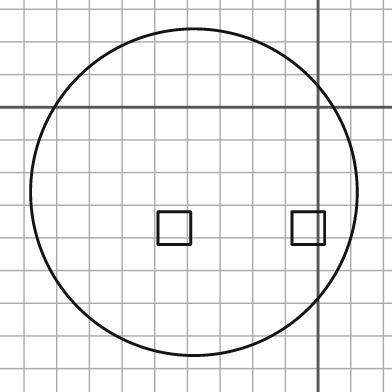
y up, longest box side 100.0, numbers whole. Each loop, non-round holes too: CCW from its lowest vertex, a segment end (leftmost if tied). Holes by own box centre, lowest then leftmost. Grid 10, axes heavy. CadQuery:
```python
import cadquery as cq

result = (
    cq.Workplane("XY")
    .moveTo(-38.0, -26.0)
    .circle(50.0)
    .moveTo(-49.0, -42.0)
    .lineTo(-39.0, -42.0)
    .lineTo(-39.0, -32.0)
    .lineTo(-49.0, -32.0)
    .close()
    .moveTo(-8.0, -42.0)
    .lineTo(2.0, -42.0)
    .lineTo(2.0, -32.0)
    .lineTo(-8.0, -32.0)
    .close()
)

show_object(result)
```